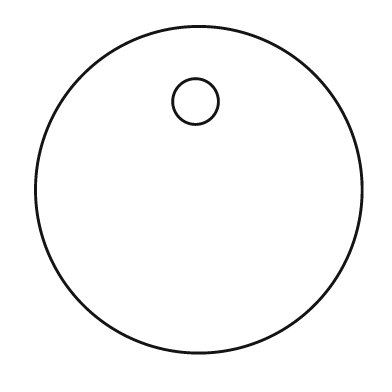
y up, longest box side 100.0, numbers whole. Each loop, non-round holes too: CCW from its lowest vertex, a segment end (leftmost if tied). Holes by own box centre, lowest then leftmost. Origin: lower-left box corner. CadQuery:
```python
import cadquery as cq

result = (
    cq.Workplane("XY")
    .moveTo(50.0, 50.0)
    .circle(50.0)
    .moveTo(49.0, 77.0)
    .circle(7.0)
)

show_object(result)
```